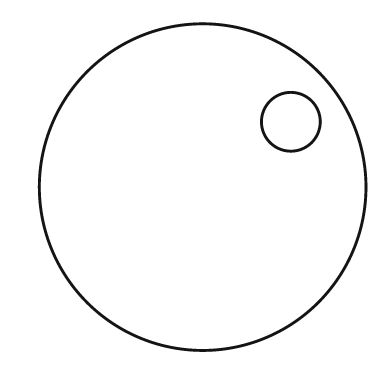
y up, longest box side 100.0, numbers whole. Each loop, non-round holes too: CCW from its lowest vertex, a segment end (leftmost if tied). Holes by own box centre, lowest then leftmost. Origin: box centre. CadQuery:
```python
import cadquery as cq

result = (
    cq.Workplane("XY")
    .moveTo(0.0, 0.0)
    .circle(50.0)
    .moveTo(27.0, 20.0)
    .circle(9.0)
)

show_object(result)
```